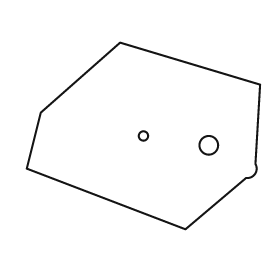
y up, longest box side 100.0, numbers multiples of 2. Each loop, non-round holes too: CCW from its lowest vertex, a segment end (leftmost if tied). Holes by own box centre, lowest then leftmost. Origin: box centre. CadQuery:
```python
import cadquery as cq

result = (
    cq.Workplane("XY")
    .moveTo(18.0, -40.0)
    .lineTo(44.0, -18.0)
    .threePointArc((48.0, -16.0), (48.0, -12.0))
    .lineTo(50.0, 22.0)
    .lineTo(-10.0, 40.0)
    .lineTo(-44.0, 10.0)
    .lineTo(-50.0, -14.0)
    .close()
    .moveTo(28.0, -4.0)
    .circle(4.0)
    .moveTo(0.0, 0.0)
    .circle(2.0)
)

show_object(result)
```